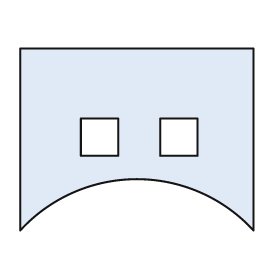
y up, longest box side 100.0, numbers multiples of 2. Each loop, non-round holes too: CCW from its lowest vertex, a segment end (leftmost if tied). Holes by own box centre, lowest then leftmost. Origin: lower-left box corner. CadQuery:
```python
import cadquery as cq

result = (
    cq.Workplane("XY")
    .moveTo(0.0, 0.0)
    .threePointArc((50.0, 22.0), (100.0, 0.0))
    .lineTo(100.0, 78.0)
    .lineTo(0.0, 78.0)
    .close()
    .moveTo(26.0, 32.0)
    .lineTo(42.0, 32.0)
    .lineTo(42.0, 48.0)
    .lineTo(26.0, 48.0)
    .close()
    .moveTo(60.0, 32.0)
    .lineTo(76.0, 32.0)
    .lineTo(76.0, 48.0)
    .lineTo(60.0, 48.0)
    .close()
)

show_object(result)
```